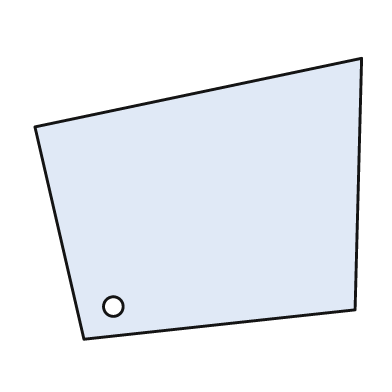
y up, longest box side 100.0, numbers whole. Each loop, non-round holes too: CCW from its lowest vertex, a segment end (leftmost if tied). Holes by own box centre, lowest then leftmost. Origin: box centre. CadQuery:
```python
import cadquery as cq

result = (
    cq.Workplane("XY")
    .moveTo(-35.0, -43.0)
    .lineTo(48.0, -34.0)
    .lineTo(50.0, 43.0)
    .lineTo(-50.0, 22.0)
    .close()
    .moveTo(-26.0, -33.0)
    .circle(3.0)
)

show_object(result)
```